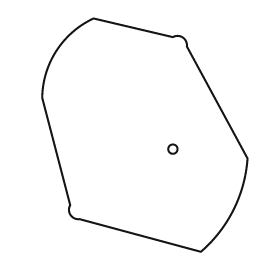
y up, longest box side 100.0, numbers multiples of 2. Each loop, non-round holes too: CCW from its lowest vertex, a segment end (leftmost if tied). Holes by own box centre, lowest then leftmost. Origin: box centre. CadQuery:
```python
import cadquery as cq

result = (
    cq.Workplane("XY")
    .moveTo(24.0, -50.0)
    .threePointArc((38.0, -32.0), (44.0, -10.0))
    .lineTo(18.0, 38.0)
    .threePointArc((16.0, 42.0), (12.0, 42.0))
    .lineTo(-22.0, 50.0)
    .threePointArc((-38.0, 36.0), (-44.0, 16.0))
    .lineTo(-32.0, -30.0)
    .threePointArc((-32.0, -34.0), (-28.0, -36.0))
    .close()
    .moveTo(12.0, -6.0)
    .circle(2.0)
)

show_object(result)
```